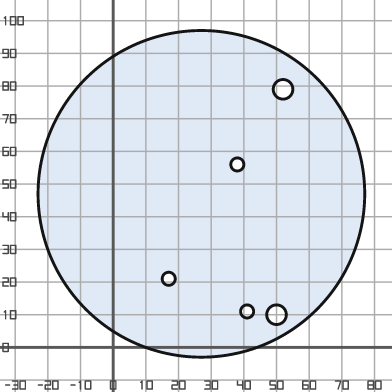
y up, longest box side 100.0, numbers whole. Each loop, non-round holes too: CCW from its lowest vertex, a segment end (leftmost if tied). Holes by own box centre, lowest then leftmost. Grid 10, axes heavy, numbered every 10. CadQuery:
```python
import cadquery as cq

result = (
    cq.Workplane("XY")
    .moveTo(27.0, 47.0)
    .circle(50.0)
    .moveTo(50.0, 10.0)
    .circle(3.0)
    .moveTo(41.0, 11.0)
    .circle(2.0)
    .moveTo(17.0, 21.0)
    .circle(2.0)
    .moveTo(38.0, 56.0)
    .circle(2.0)
    .moveTo(52.0, 79.0)
    .circle(3.0)
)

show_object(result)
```